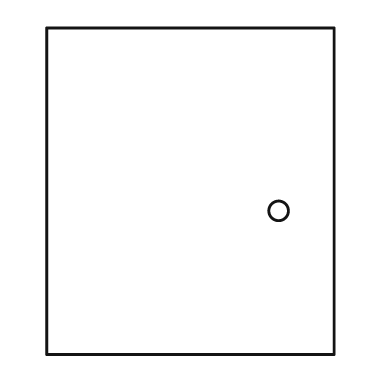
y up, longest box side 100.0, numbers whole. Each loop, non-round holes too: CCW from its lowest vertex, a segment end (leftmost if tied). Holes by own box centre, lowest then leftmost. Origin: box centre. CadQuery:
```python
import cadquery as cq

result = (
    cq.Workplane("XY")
    .moveTo(-44.0, -50.0)
    .lineTo(44.0, -50.0)
    .lineTo(44.0, 50.0)
    .lineTo(-44.0, 50.0)
    .close()
    .moveTo(27.0, -6.0)
    .circle(3.0)
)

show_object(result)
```